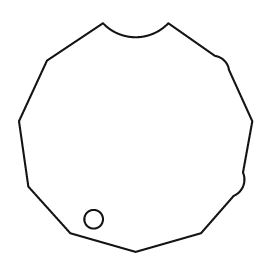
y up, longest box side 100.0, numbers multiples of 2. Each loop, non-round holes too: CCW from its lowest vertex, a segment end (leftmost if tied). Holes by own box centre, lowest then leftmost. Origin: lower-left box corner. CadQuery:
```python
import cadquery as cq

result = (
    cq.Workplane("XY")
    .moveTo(50.0, 0.0)
    .lineTo(78.0, 8.0)
    .lineTo(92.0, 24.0)
    .threePointArc((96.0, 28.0), (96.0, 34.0))
    .lineTo(100.0, 56.0)
    .lineTo(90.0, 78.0)
    .threePointArc((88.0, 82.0), (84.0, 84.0))
    .lineTo(64.0, 98.0)
    .threePointArc((50.0, 92.0), (36.0, 98.0))
    .lineTo(12.0, 82.0)
    .lineTo(0.0, 56.0)
    .lineTo(4.0, 28.0)
    .lineTo(22.0, 8.0)
    .close()
    .moveTo(32.0, 14.0)
    .circle(4.0)
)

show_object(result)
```